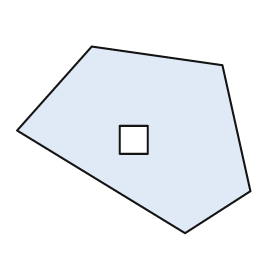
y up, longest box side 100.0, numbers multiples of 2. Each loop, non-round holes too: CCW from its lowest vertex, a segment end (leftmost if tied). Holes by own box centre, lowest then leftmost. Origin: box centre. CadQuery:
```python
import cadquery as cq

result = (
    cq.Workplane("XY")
    .moveTo(22.0, -40.0)
    .lineTo(50.0, -22.0)
    .lineTo(38.0, 32.0)
    .lineTo(-18.0, 40.0)
    .lineTo(-50.0, 4.0)
    .close()
    .moveTo(-6.0, -6.0)
    .lineTo(6.0, -6.0)
    .lineTo(6.0, 6.0)
    .lineTo(-6.0, 6.0)
    .close()
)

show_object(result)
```